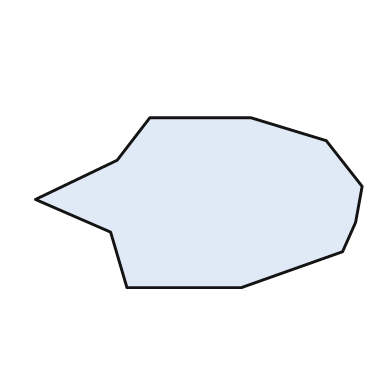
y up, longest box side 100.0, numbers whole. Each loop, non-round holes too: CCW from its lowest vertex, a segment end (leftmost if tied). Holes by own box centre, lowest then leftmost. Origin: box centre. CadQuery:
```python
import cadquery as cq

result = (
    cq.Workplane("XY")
    .moveTo(-22.0, -26.0)
    .lineTo(13.0, -26.0)
    .lineTo(44.0, -15.0)
    .lineTo(48.0, -6.0)
    .lineTo(50.0, 5.0)
    .lineTo(39.0, 19.0)
    .lineTo(16.0, 26.0)
    .lineTo(-15.0, 26.0)
    .lineTo(-25.0, 13.0)
    .lineTo(-50.0, 1.0)
    .lineTo(-27.0, -9.0)
    .close()
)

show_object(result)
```